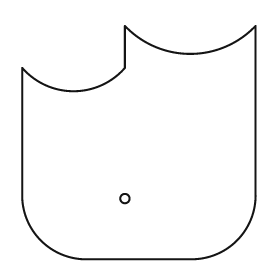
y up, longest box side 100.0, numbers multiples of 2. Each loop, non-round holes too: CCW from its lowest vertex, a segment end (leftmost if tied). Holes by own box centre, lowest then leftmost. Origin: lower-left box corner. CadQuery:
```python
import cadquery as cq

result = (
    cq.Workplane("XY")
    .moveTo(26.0, 0.0)
    .lineTo(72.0, 0.0)
    .threePointArc((92.0, 8.0), (100.0, 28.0))
    .lineTo(100.0, 100.0)
    .threePointArc((72.0, 88.0), (44.0, 100.0))
    .lineTo(44.0, 82.0)
    .threePointArc((22.0, 72.0), (0.0, 82.0))
    .lineTo(0.0, 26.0)
    .threePointArc((8.0, 8.0), (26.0, 0.0))
    .close()
    .moveTo(44.0, 26.0)
    .circle(2.0)
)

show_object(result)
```